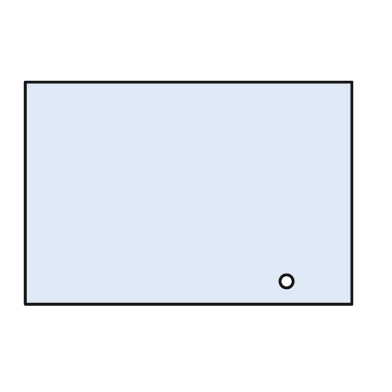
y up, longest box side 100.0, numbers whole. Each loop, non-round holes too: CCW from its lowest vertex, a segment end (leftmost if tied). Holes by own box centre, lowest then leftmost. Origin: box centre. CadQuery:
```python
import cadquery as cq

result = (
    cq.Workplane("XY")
    .moveTo(-50.0, -34.0)
    .lineTo(50.0, -34.0)
    .lineTo(50.0, 34.0)
    .lineTo(-50.0, 34.0)
    .close()
    .moveTo(30.0, -27.0)
    .circle(2.0)
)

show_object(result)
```